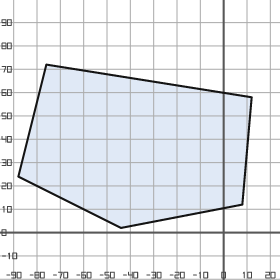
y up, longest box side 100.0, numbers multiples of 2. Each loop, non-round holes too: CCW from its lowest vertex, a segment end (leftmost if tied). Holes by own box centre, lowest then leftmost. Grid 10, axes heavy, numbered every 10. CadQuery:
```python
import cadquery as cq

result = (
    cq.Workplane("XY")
    .moveTo(-44.0, 2.0)
    .lineTo(8.0, 12.0)
    .lineTo(12.0, 58.0)
    .lineTo(-76.0, 72.0)
    .lineTo(-88.0, 24.0)
    .close()
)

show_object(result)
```